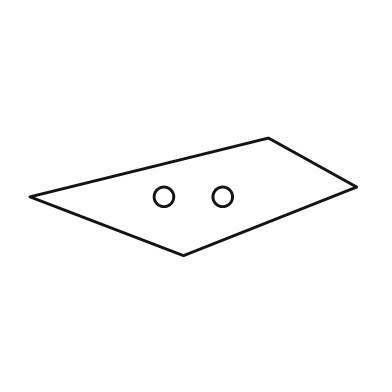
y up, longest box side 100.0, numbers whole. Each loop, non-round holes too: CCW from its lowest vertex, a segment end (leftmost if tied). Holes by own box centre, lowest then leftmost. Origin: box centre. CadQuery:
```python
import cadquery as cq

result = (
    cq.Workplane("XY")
    .moveTo(-3.0, -18.0)
    .lineTo(50.0, 3.0)
    .lineTo(23.0, 18.0)
    .lineTo(-50.0, 0.0)
    .close()
    .moveTo(-9.0, 0.0)
    .circle(3.0)
    .moveTo(9.0, 0.0)
    .circle(3.0)
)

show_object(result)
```